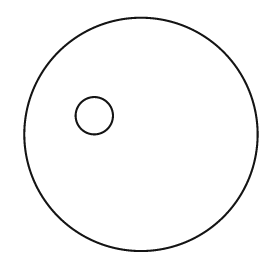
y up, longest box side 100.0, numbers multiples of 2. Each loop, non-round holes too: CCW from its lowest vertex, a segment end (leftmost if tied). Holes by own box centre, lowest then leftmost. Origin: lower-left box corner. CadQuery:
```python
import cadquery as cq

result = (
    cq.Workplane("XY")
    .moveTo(50.0, 50.0)
    .circle(50.0)
    .moveTo(30.0, 58.0)
    .circle(8.0)
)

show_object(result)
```